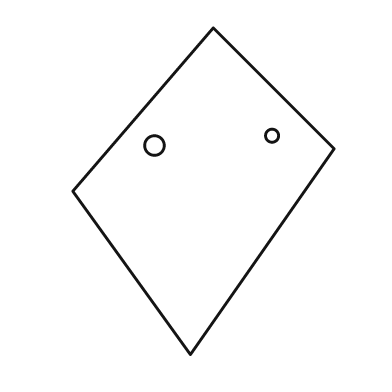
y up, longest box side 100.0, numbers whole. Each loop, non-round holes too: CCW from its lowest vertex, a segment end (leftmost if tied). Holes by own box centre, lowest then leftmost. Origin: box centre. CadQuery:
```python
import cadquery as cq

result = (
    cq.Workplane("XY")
    .moveTo(-4.0, -50.0)
    .lineTo(40.0, 13.0)
    .lineTo(3.0, 50.0)
    .lineTo(-40.0, 0.0)
    .close()
    .moveTo(-15.0, 14.0)
    .circle(3.0)
    .moveTo(21.0, 17.0)
    .circle(2.0)
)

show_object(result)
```